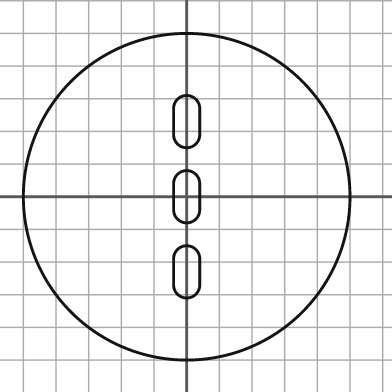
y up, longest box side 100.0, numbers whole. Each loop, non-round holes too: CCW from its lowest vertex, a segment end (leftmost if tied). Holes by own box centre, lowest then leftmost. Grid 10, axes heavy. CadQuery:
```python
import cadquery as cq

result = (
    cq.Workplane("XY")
    .moveTo(0.0, 0.0)
    .circle(50.0)
    .moveTo(-4.0, -27.0)
    .threePointArc((0.0, -31.0), (4.0, -27.0))
    .lineTo(4.0, -19.0)
    .threePointArc((0.0, -15.0), (-4.0, -19.0))
    .close()
    .moveTo(-4.0, -4.0)
    .threePointArc((0.0, -8.0), (4.0, -4.0))
    .lineTo(4.0, 4.0)
    .threePointArc((0.0, 8.0), (-4.0, 4.0))
    .close()
    .moveTo(-4.0, 19.0)
    .threePointArc((0.0, 15.0), (4.0, 19.0))
    .lineTo(4.0, 27.0)
    .threePointArc((0.0, 31.0), (-4.0, 27.0))
    .close()
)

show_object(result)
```